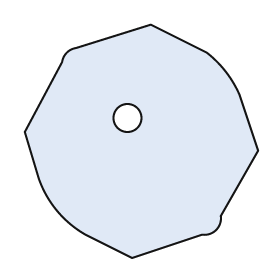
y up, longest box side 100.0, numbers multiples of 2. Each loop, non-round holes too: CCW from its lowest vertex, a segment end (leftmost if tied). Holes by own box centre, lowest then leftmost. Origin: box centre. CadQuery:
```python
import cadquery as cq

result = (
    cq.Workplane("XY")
    .moveTo(-4.0, -50.0)
    .lineTo(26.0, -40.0)
    .threePointArc((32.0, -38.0), (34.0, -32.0))
    .lineTo(50.0, -4.0)
    .lineTo(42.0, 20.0)
    .threePointArc((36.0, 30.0), (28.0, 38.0))
    .lineTo(4.0, 50.0)
    .lineTo(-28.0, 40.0)
    .threePointArc((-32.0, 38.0), (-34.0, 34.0))
    .lineTo(-50.0, 4.0)
    .lineTo(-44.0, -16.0)
    .threePointArc((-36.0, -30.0), (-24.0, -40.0))
    .close()
    .moveTo(-6.0, 10.0)
    .circle(6.0)
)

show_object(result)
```